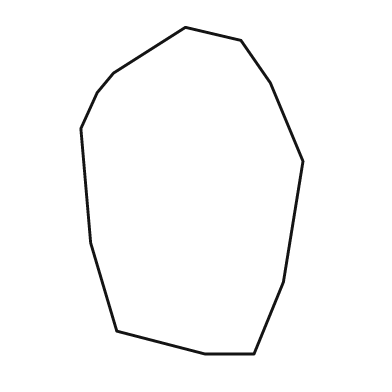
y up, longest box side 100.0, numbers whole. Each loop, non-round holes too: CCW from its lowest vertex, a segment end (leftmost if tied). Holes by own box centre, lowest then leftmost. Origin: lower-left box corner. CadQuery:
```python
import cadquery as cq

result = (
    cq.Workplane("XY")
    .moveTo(38.0, 0.0)
    .lineTo(53.0, 0.0)
    .lineTo(62.0, 22.0)
    .lineTo(68.0, 59.0)
    .lineTo(58.0, 83.0)
    .lineTo(49.0, 96.0)
    .lineTo(32.0, 100.0)
    .lineTo(10.0, 86.0)
    .lineTo(5.0, 80.0)
    .lineTo(0.0, 69.0)
    .lineTo(3.0, 34.0)
    .lineTo(11.0, 7.0)
    .close()
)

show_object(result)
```